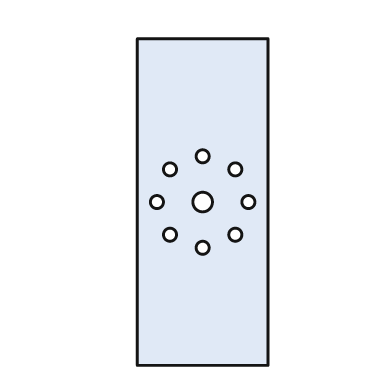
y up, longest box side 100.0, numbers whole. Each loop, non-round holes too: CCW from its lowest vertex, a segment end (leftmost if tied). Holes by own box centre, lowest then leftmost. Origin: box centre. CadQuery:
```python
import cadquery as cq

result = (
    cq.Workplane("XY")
    .moveTo(-20.0, -50.0)
    .lineTo(20.0, -50.0)
    .lineTo(20.0, 50.0)
    .lineTo(-20.0, 50.0)
    .close()
    .moveTo(0.0, -14.0)
    .circle(2.0)
    .moveTo(-10.0, -10.0)
    .circle(2.0)
    .moveTo(10.0, -10.0)
    .circle(2.0)
    .moveTo(-14.0, 0.0)
    .circle(2.0)
    .moveTo(0.0, 0.0)
    .circle(3.0)
    .moveTo(14.0, 0.0)
    .circle(2.0)
    .moveTo(-10.0, 10.0)
    .circle(2.0)
    .moveTo(10.0, 10.0)
    .circle(2.0)
    .moveTo(0.0, 14.0)
    .circle(2.0)
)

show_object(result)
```